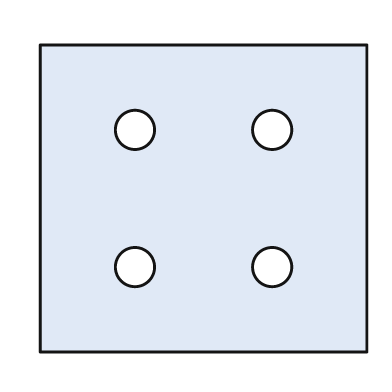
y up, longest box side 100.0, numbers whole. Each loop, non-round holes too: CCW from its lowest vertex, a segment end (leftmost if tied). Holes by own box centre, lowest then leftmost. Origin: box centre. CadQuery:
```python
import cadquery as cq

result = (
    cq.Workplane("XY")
    .moveTo(-50.0, -47.0)
    .lineTo(50.0, -47.0)
    .lineTo(50.0, 47.0)
    .lineTo(-50.0, 47.0)
    .close()
    .moveTo(-21.0, -21.0)
    .circle(6.0)
    .moveTo(21.0, -21.0)
    .circle(6.0)
    .moveTo(-21.0, 21.0)
    .circle(6.0)
    .moveTo(21.0, 21.0)
    .circle(6.0)
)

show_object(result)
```